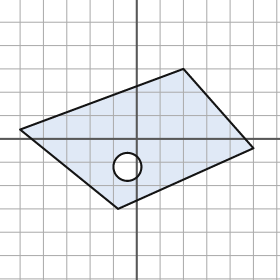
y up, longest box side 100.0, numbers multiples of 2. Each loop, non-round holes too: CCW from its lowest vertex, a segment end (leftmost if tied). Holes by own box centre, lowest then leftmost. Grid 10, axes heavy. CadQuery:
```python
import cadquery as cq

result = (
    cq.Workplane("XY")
    .moveTo(-8.0, -30.0)
    .lineTo(50.0, -4.0)
    .lineTo(20.0, 30.0)
    .lineTo(-50.0, 4.0)
    .close()
    .moveTo(-4.0, -12.0)
    .circle(6.0)
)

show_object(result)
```